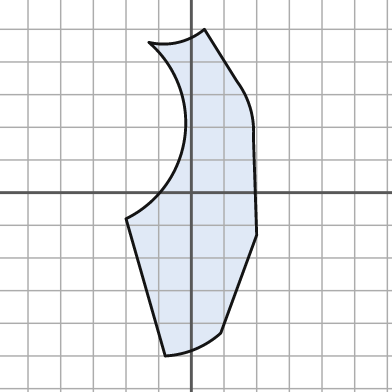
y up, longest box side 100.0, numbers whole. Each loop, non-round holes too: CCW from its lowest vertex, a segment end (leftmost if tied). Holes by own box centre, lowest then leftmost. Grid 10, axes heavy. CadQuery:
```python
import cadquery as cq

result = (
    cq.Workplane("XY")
    .moveTo(-8.0, -50.0)
    .threePointArc((1.0, -48.0), (9.0, -43.0))
    .lineTo(20.0, -13.0)
    .lineTo(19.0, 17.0)
    .threePointArc((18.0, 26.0), (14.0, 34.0))
    .lineTo(4.0, 50.0)
    .threePointArc((-4.0, 46.0), (-13.0, 46.0))
    .threePointArc((-2.0, 17.0), (-20.0, -8.0))
    .close()
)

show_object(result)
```